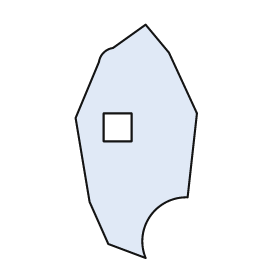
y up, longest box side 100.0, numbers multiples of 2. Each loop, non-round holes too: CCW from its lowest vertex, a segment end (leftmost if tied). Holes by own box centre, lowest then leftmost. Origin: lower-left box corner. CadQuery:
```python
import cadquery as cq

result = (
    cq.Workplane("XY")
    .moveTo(30.0, 0.0)
    .threePointArc((32.0, 18.0), (48.0, 26.0))
    .lineTo(52.0, 62.0)
    .lineTo(40.0, 88.0)
    .lineTo(30.0, 100.0)
    .lineTo(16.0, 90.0)
    .threePointArc((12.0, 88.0), (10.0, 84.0))
    .lineTo(0.0, 60.0)
    .lineTo(6.0, 24.0)
    .lineTo(14.0, 6.0)
    .close()
    .moveTo(12.0, 50.0)
    .lineTo(24.0, 50.0)
    .lineTo(24.0, 62.0)
    .lineTo(12.0, 62.0)
    .close()
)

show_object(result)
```